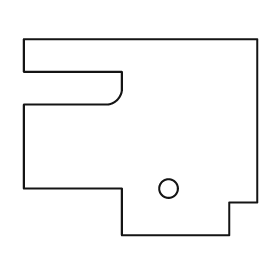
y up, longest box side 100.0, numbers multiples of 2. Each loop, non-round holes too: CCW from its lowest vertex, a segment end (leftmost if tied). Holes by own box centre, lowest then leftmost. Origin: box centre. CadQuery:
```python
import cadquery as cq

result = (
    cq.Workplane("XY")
    .moveTo(-8.0, -42.0)
    .lineTo(38.0, -42.0)
    .lineTo(38.0, -28.0)
    .lineTo(50.0, -28.0)
    .lineTo(50.0, 42.0)
    .lineTo(-50.0, 42.0)
    .lineTo(-50.0, 28.0)
    .lineTo(-8.0, 28.0)
    .lineTo(-8.0, 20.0)
    .threePointArc((-10.0, 16.0), (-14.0, 14.0))
    .lineTo(-50.0, 14.0)
    .lineTo(-50.0, -22.0)
    .lineTo(-8.0, -22.0)
    .close()
    .moveTo(12.0, -22.0)
    .circle(4.0)
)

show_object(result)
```